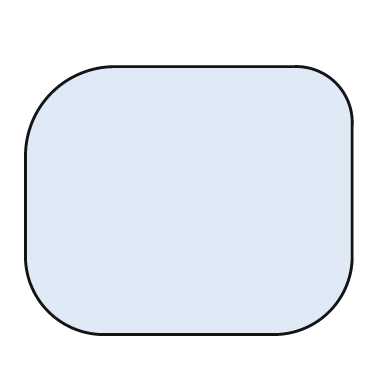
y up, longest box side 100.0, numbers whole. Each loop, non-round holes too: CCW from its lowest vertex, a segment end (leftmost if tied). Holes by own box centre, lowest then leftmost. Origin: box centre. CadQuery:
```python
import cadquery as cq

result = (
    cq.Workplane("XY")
    .moveTo(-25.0, -41.0)
    .lineTo(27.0, -41.0)
    .threePointArc((43.0, -34.0), (50.0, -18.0))
    .lineTo(50.0, 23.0)
    .threePointArc((45.0, 36.0), (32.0, 41.0))
    .lineTo(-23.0, 41.0)
    .threePointArc((-42.0, 33.0), (-50.0, 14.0))
    .lineTo(-50.0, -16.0)
    .threePointArc((-43.0, -34.0), (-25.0, -41.0))
    .close()
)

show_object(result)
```